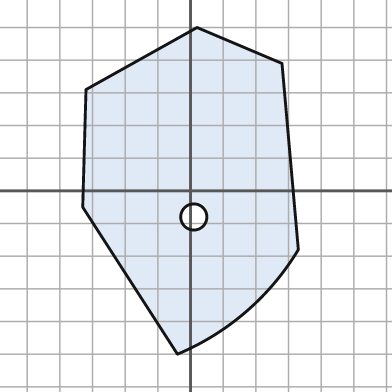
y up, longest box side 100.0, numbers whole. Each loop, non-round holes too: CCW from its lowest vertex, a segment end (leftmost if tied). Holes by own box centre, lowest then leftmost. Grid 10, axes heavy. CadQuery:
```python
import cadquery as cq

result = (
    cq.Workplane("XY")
    .moveTo(-4.0, -50.0)
    .threePointArc((17.0, -37.0), (33.0, -18.0))
    .lineTo(28.0, 39.0)
    .lineTo(2.0, 50.0)
    .lineTo(-32.0, 31.0)
    .lineTo(-33.0, -5.0)
    .close()
    .moveTo(1.0, -8.0)
    .circle(4.0)
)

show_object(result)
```